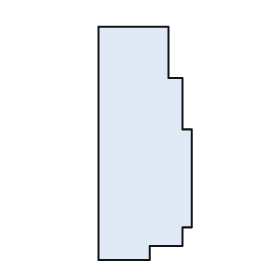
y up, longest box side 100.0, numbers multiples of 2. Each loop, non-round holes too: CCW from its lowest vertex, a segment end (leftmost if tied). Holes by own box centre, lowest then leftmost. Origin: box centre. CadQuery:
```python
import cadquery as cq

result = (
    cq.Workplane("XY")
    .moveTo(-20.0, -50.0)
    .lineTo(2.0, -50.0)
    .lineTo(2.0, -44.0)
    .lineTo(16.0, -44.0)
    .lineTo(16.0, -36.0)
    .lineTo(20.0, -36.0)
    .lineTo(20.0, 6.0)
    .lineTo(16.0, 6.0)
    .lineTo(16.0, 28.0)
    .lineTo(10.0, 28.0)
    .lineTo(10.0, 50.0)
    .lineTo(-20.0, 50.0)
    .close()
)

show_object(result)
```